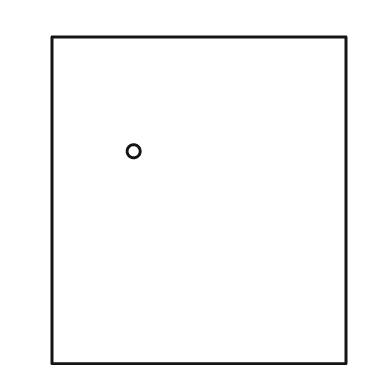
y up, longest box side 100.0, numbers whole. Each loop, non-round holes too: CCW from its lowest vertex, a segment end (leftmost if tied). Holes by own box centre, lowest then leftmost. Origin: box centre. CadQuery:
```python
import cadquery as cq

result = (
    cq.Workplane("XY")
    .moveTo(-45.0, -50.0)
    .lineTo(45.0, -50.0)
    .lineTo(45.0, 50.0)
    .lineTo(-45.0, 50.0)
    .close()
    .moveTo(-20.0, 15.0)
    .circle(2.0)
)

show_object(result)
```